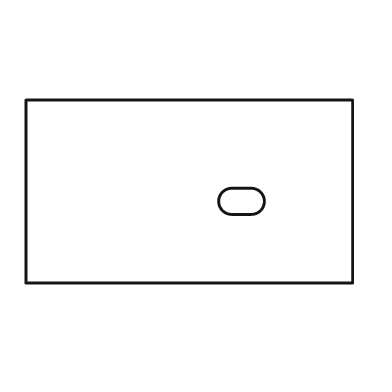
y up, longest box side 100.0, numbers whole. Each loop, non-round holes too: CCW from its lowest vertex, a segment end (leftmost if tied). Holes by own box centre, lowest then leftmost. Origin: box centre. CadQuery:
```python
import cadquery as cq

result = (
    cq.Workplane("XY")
    .moveTo(-50.0, -28.0)
    .lineTo(50.0, -28.0)
    .lineTo(50.0, 28.0)
    .lineTo(-50.0, 28.0)
    .close()
    .moveTo(13.0, -7.0)
    .lineTo(19.0, -7.0)
    .threePointArc((23.0, -3.0), (19.0, 1.0))
    .lineTo(13.0, 1.0)
    .threePointArc((9.0, -3.0), (13.0, -7.0))
    .close()
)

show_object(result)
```